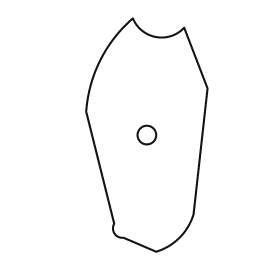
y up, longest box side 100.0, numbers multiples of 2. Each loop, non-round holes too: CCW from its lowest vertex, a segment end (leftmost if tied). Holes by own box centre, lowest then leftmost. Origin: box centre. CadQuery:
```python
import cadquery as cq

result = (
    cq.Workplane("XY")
    .moveTo(4.0, -50.0)
    .threePointArc((14.0, -44.0), (20.0, -34.0))
    .lineTo(26.0, 20.0)
    .lineTo(16.0, 46.0)
    .threePointArc((4.0, 42.0), (-6.0, 50.0))
    .threePointArc((-20.0, 32.0), (-26.0, 10.0))
    .lineTo(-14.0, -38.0)
    .threePointArc((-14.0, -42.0), (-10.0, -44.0))
    .close()
    .moveTo(0.0, 0.0)
    .circle(4.0)
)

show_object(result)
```